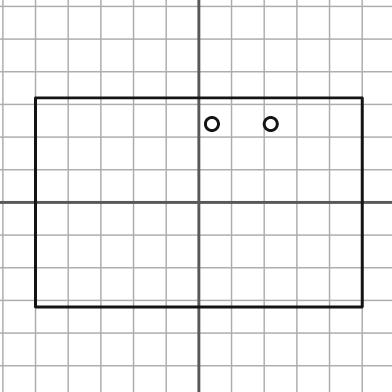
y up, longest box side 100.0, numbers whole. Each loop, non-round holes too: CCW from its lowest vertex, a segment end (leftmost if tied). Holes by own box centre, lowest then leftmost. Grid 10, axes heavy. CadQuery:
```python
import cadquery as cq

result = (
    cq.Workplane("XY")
    .moveTo(-50.0, -32.0)
    .lineTo(50.0, -32.0)
    .lineTo(50.0, 32.0)
    .lineTo(-50.0, 32.0)
    .close()
    .moveTo(4.0, 24.0)
    .circle(2.0)
    .moveTo(22.0, 24.0)
    .circle(2.0)
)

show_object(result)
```